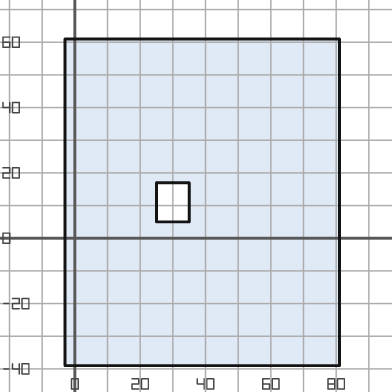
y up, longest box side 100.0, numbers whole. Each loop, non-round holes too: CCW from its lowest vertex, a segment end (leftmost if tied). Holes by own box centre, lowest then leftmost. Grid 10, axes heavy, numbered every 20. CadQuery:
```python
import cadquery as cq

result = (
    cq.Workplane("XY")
    .moveTo(-3.0, -39.0)
    .lineTo(81.0, -39.0)
    .lineTo(81.0, 61.0)
    .lineTo(-3.0, 61.0)
    .close()
    .moveTo(25.0, 5.0)
    .lineTo(35.0, 5.0)
    .lineTo(35.0, 17.0)
    .lineTo(25.0, 17.0)
    .close()
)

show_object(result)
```